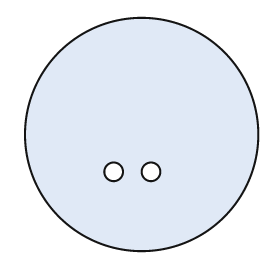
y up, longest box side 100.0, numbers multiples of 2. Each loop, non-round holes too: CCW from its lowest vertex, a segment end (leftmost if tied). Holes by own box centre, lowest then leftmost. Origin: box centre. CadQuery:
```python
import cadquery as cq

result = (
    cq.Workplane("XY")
    .moveTo(0.0, 0.0)
    .circle(50.0)
    .moveTo(-12.0, -16.0)
    .circle(4.0)
    .moveTo(4.0, -16.0)
    .circle(4.0)
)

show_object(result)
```